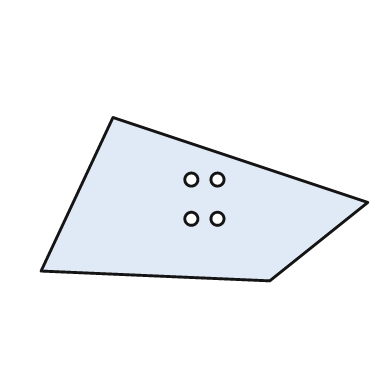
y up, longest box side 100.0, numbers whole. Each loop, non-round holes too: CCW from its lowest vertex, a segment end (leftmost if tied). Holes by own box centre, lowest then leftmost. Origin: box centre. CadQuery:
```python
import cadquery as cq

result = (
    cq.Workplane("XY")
    .moveTo(20.0, -25.0)
    .lineTo(50.0, -1.0)
    .lineTo(-28.0, 25.0)
    .lineTo(-50.0, -22.0)
    .close()
    .moveTo(-4.0, -6.0)
    .circle(2.0)
    .moveTo(4.0, -6.0)
    .circle(2.0)
    .moveTo(-4.0, 6.0)
    .circle(2.0)
    .moveTo(4.0, 6.0)
    .circle(2.0)
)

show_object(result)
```